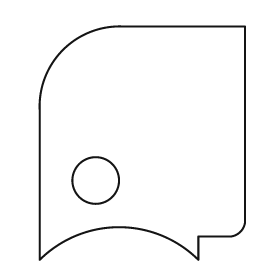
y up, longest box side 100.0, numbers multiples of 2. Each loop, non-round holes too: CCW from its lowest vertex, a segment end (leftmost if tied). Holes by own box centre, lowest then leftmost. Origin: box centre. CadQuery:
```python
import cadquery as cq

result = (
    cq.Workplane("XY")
    .moveTo(-44.0, -50.0)
    .threePointArc((-10.0, -36.0), (24.0, -50.0))
    .lineTo(24.0, -40.0)
    .lineTo(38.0, -40.0)
    .threePointArc((42.0, -38.0), (44.0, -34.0))
    .lineTo(44.0, 50.0)
    .lineTo(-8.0, 50.0)
    .threePointArc((-34.0, 40.0), (-44.0, 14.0))
    .close()
    .moveTo(-20.0, -16.0)
    .circle(10.0)
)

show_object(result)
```